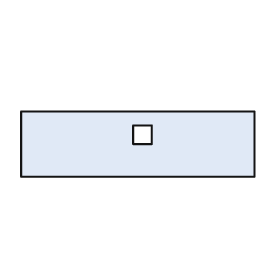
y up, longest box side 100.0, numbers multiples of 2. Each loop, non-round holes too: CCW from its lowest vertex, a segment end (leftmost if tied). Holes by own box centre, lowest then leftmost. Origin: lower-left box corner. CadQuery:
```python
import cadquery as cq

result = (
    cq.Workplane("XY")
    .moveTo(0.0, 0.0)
    .lineTo(100.0, 0.0)
    .lineTo(100.0, 28.0)
    .lineTo(0.0, 28.0)
    .close()
    .moveTo(48.0, 14.0)
    .lineTo(56.0, 14.0)
    .lineTo(56.0, 22.0)
    .lineTo(48.0, 22.0)
    .close()
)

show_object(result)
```